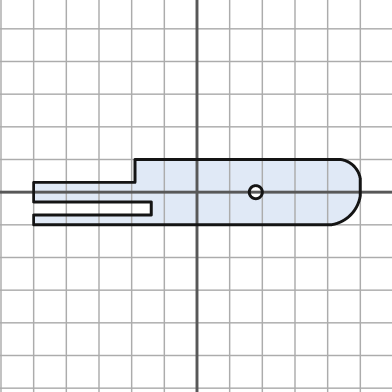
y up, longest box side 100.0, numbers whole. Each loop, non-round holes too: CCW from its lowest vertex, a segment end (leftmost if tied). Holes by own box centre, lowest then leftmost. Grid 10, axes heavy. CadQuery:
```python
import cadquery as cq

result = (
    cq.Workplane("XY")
    .moveTo(-50.0, -10.0)
    .lineTo(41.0, -10.0)
    .threePointArc((47.0, -7.0), (50.0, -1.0))
    .lineTo(50.0, 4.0)
    .threePointArc((48.0, 8.0), (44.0, 10.0))
    .lineTo(-19.0, 10.0)
    .lineTo(-19.0, 3.0)
    .lineTo(-50.0, 3.0)
    .lineTo(-50.0, -3.0)
    .lineTo(-14.0, -3.0)
    .lineTo(-14.0, -7.0)
    .lineTo(-50.0, -7.0)
    .close()
    .moveTo(18.0, 0.0)
    .circle(2.0)
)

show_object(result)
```